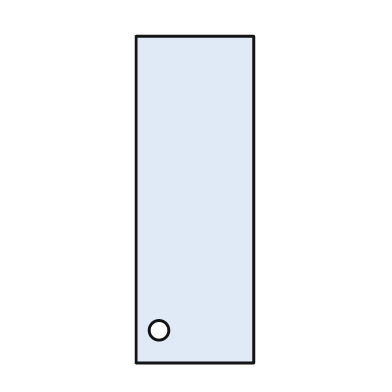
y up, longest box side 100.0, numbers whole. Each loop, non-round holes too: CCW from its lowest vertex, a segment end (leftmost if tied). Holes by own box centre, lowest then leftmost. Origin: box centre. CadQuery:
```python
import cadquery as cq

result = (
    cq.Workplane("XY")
    .moveTo(-18.0, -50.0)
    .lineTo(18.0, -50.0)
    .lineTo(18.0, 50.0)
    .lineTo(-18.0, 50.0)
    .close()
    .moveTo(-11.0, -40.0)
    .circle(3.0)
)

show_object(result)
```